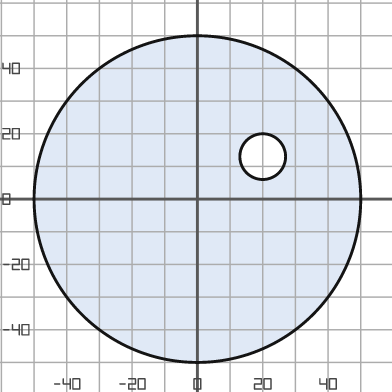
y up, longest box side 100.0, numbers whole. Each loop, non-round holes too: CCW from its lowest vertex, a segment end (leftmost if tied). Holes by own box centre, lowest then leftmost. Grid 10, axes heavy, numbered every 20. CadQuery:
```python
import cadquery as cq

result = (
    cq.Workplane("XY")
    .moveTo(0.0, 0.0)
    .circle(50.0)
    .moveTo(20.0, 13.0)
    .circle(7.0)
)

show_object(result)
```